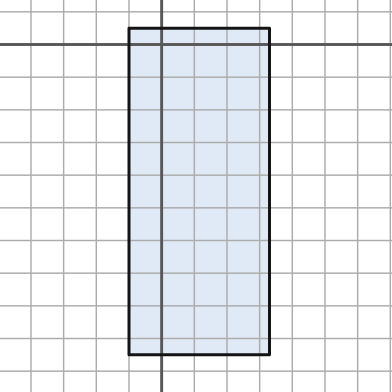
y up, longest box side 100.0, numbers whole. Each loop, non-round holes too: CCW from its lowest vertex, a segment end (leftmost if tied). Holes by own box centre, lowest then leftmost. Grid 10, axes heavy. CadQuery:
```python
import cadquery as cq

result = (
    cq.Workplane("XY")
    .moveTo(-10.0, -95.0)
    .lineTo(33.0, -95.0)
    .lineTo(33.0, 5.0)
    .lineTo(-10.0, 5.0)
    .close()
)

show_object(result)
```